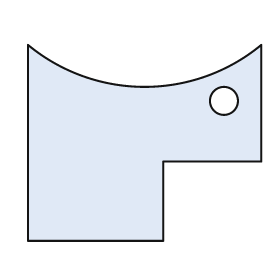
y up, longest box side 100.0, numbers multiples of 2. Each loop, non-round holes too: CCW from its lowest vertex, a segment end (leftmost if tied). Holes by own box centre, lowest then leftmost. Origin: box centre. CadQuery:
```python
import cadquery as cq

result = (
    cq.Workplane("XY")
    .moveTo(-50.0, -42.0)
    .lineTo(8.0, -42.0)
    .lineTo(8.0, -8.0)
    .lineTo(50.0, -8.0)
    .lineTo(50.0, 42.0)
    .threePointArc((0.0, 24.0), (-50.0, 42.0))
    .close()
    .moveTo(34.0, 18.0)
    .circle(6.0)
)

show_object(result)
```